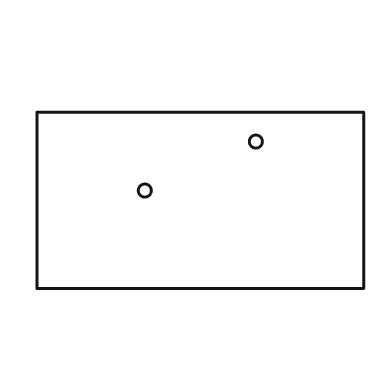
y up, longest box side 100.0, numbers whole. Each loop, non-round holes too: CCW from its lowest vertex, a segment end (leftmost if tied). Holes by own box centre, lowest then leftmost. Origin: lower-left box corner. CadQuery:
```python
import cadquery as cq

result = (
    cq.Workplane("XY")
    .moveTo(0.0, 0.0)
    .lineTo(100.0, 0.0)
    .lineTo(100.0, 54.0)
    .lineTo(0.0, 54.0)
    .close()
    .moveTo(33.0, 30.0)
    .circle(2.0)
    .moveTo(67.0, 45.0)
    .circle(2.0)
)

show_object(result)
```